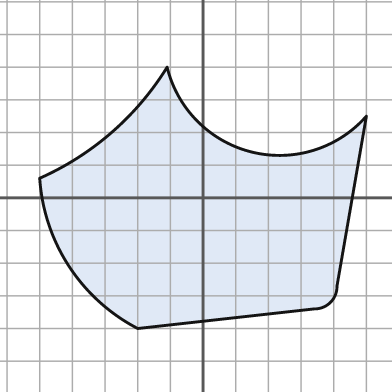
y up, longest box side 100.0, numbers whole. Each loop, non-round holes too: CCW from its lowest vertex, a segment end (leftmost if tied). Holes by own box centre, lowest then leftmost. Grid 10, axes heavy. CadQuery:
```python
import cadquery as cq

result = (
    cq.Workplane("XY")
    .moveTo(-20.0, -40.0)
    .lineTo(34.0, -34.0)
    .threePointArc((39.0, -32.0), (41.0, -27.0))
    .lineTo(50.0, 25.0)
    .threePointArc((15.0, 14.0), (-11.0, 40.0))
    .threePointArc((-28.0, 20.0), (-50.0, 6.0))
    .threePointArc((-41.0, -21.0), (-20.0, -40.0))
    .close()
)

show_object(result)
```